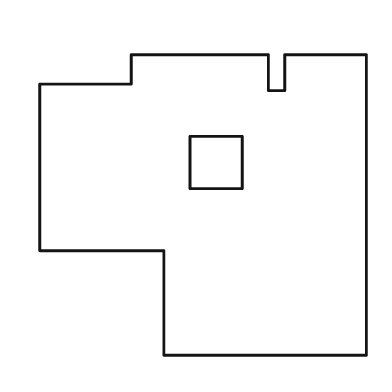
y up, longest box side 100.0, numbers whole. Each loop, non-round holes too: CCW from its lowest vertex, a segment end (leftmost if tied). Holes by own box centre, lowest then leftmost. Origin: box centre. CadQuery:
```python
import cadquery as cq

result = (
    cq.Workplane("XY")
    .moveTo(-12.0, -46.0)
    .lineTo(50.0, -46.0)
    .lineTo(50.0, 46.0)
    .lineTo(25.0, 46.0)
    .lineTo(25.0, 35.0)
    .lineTo(20.0, 35.0)
    .lineTo(20.0, 46.0)
    .lineTo(-22.0, 46.0)
    .lineTo(-22.0, 37.0)
    .lineTo(-50.0, 37.0)
    .lineTo(-50.0, -14.0)
    .lineTo(-12.0, -14.0)
    .close()
    .moveTo(-4.0, 5.0)
    .lineTo(12.0, 5.0)
    .lineTo(12.0, 21.0)
    .lineTo(-4.0, 21.0)
    .close()
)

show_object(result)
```